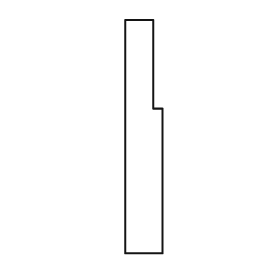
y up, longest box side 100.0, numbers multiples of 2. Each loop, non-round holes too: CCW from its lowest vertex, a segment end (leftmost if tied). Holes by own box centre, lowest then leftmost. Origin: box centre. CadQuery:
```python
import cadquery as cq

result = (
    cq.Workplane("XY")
    .moveTo(-8.0, -50.0)
    .lineTo(8.0, -50.0)
    .lineTo(8.0, 12.0)
    .lineTo(4.0, 12.0)
    .lineTo(4.0, 50.0)
    .lineTo(-8.0, 50.0)
    .close()
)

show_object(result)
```